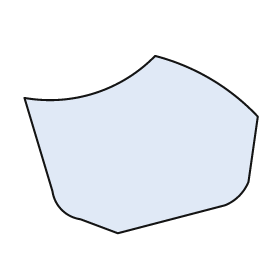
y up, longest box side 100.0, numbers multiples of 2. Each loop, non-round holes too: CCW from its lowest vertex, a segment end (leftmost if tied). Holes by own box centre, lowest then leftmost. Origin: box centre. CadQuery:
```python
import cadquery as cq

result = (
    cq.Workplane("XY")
    .moveTo(-10.0, -38.0)
    .lineTo(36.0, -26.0)
    .threePointArc((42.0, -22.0), (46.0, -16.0))
    .lineTo(50.0, 12.0)
    .threePointArc((30.0, 28.0), (6.0, 38.0))
    .threePointArc((-20.0, 22.0), (-50.0, 20.0))
    .lineTo(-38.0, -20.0)
    .threePointArc((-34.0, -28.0), (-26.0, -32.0))
    .close()
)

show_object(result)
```